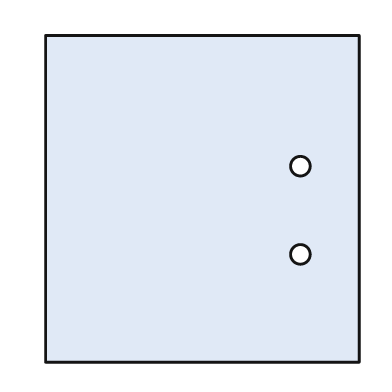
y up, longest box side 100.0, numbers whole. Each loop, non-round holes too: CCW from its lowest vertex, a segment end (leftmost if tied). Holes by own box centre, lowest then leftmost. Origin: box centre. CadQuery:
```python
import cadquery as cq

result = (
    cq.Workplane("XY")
    .moveTo(-48.0, -50.0)
    .lineTo(48.0, -50.0)
    .lineTo(48.0, 50.0)
    .lineTo(-48.0, 50.0)
    .close()
    .moveTo(30.0, -17.0)
    .circle(3.0)
    .moveTo(30.0, 10.0)
    .circle(3.0)
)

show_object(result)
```